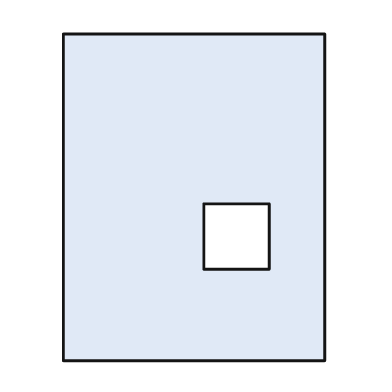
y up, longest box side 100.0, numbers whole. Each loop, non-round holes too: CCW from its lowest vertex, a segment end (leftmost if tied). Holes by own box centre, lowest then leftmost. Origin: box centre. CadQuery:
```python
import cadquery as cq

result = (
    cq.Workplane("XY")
    .moveTo(-40.0, -50.0)
    .lineTo(40.0, -50.0)
    .lineTo(40.0, 50.0)
    .lineTo(-40.0, 50.0)
    .close()
    .moveTo(3.0, -22.0)
    .lineTo(23.0, -22.0)
    .lineTo(23.0, -2.0)
    .lineTo(3.0, -2.0)
    .close()
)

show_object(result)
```